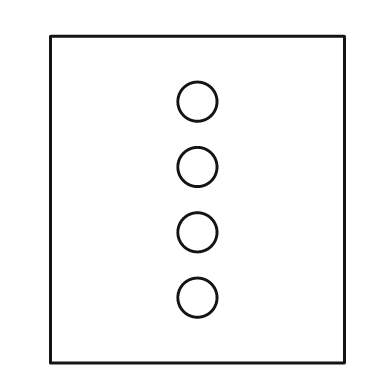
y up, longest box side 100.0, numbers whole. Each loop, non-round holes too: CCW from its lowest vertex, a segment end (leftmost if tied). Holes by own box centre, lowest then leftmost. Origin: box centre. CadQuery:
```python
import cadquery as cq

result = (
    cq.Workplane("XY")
    .moveTo(-45.0, -50.0)
    .lineTo(45.0, -50.0)
    .lineTo(45.0, 50.0)
    .lineTo(-45.0, 50.0)
    .close()
    .moveTo(0.0, -30.0)
    .circle(6.0)
    .moveTo(0.0, -10.0)
    .circle(6.0)
    .moveTo(0.0, 10.0)
    .circle(6.0)
    .moveTo(0.0, 30.0)
    .circle(6.0)
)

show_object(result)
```